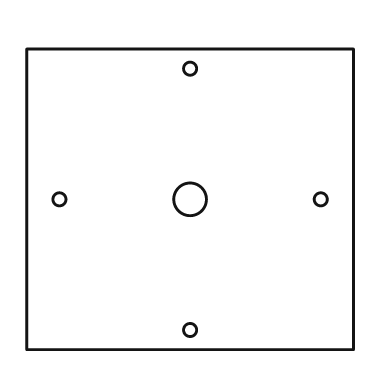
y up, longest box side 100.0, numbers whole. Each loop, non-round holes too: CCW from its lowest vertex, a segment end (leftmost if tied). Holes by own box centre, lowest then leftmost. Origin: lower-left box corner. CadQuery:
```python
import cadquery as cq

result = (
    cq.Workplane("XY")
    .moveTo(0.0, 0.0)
    .lineTo(100.0, 0.0)
    .lineTo(100.0, 92.0)
    .lineTo(0.0, 92.0)
    .close()
    .moveTo(50.0, 6.0)
    .circle(2.0)
    .moveTo(10.0, 46.0)
    .circle(2.0)
    .moveTo(50.0, 46.0)
    .circle(5.0)
    .moveTo(90.0, 46.0)
    .circle(2.0)
    .moveTo(50.0, 86.0)
    .circle(2.0)
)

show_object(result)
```